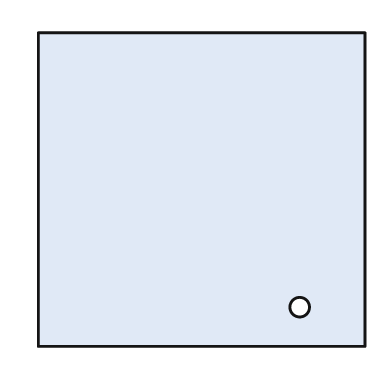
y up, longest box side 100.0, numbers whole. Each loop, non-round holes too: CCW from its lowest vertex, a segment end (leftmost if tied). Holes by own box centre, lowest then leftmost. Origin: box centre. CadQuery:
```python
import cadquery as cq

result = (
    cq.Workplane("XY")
    .moveTo(-50.0, -48.0)
    .lineTo(50.0, -48.0)
    .lineTo(50.0, 48.0)
    .lineTo(-50.0, 48.0)
    .close()
    .moveTo(30.0, -36.0)
    .circle(3.0)
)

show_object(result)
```